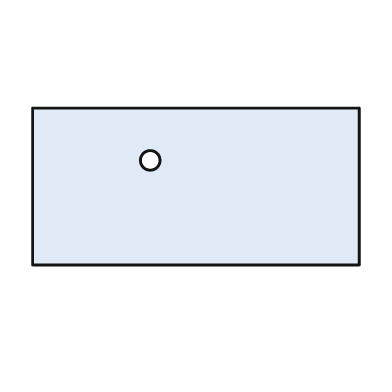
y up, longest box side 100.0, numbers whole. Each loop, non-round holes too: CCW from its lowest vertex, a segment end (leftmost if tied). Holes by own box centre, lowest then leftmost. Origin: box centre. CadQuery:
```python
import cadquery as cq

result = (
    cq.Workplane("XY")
    .moveTo(-50.0, -24.0)
    .lineTo(50.0, -24.0)
    .lineTo(50.0, 24.0)
    .lineTo(-50.0, 24.0)
    .close()
    .moveTo(-14.0, 8.0)
    .circle(3.0)
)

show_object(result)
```